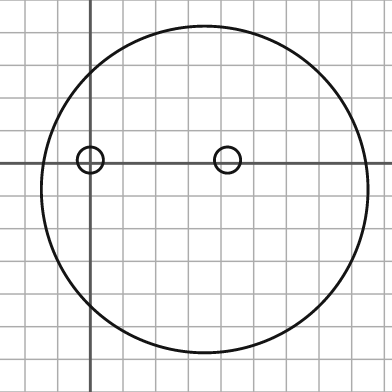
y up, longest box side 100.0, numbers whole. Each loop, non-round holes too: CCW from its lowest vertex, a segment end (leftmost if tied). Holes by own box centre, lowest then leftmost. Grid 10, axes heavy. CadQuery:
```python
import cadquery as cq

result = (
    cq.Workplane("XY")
    .moveTo(35.0, -8.0)
    .circle(50.0)
    .moveTo(0.0, 1.0)
    .circle(4.0)
    .moveTo(42.0, 1.0)
    .circle(4.0)
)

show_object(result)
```